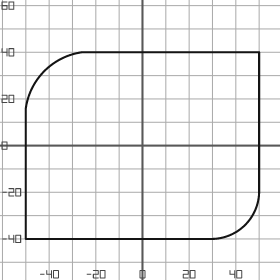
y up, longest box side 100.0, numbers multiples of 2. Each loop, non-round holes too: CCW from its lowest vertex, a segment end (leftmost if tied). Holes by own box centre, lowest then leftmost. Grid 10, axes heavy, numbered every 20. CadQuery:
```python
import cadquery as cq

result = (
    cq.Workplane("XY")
    .moveTo(-50.0, -40.0)
    .lineTo(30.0, -40.0)
    .threePointArc((44.0, -34.0), (50.0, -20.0))
    .lineTo(50.0, 40.0)
    .lineTo(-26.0, 40.0)
    .threePointArc((-42.0, 32.0), (-50.0, 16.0))
    .close()
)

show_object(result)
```